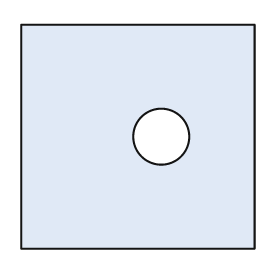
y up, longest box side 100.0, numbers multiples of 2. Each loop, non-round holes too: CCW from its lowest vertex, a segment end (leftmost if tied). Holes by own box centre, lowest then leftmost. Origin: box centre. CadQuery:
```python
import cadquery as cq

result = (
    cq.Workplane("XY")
    .moveTo(-50.0, -48.0)
    .lineTo(50.0, -48.0)
    .lineTo(50.0, 48.0)
    .lineTo(-50.0, 48.0)
    .close()
    .moveTo(10.0, 0.0)
    .circle(12.0)
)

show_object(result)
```